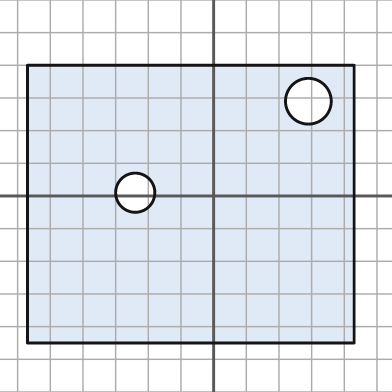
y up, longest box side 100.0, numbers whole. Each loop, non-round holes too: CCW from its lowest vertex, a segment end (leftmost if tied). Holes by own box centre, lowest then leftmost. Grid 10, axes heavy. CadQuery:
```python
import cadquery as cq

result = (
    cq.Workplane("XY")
    .moveTo(-57.0, -45.0)
    .lineTo(43.0, -45.0)
    .lineTo(43.0, 40.0)
    .lineTo(-57.0, 40.0)
    .close()
    .moveTo(-24.0, 1.0)
    .circle(6.0)
    .moveTo(29.0, 29.0)
    .circle(7.0)
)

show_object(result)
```